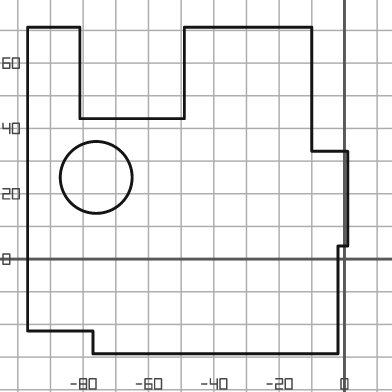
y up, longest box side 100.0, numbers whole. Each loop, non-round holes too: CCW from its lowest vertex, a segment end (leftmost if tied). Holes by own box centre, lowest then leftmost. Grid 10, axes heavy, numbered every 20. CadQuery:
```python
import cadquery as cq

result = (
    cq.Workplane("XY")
    .moveTo(-77.0, -29.0)
    .lineTo(-2.0, -29.0)
    .lineTo(-2.0, 4.0)
    .lineTo(1.0, 4.0)
    .lineTo(1.0, 33.0)
    .lineTo(-10.0, 33.0)
    .lineTo(-10.0, 71.0)
    .lineTo(-49.0, 71.0)
    .lineTo(-49.0, 43.0)
    .lineTo(-81.0, 43.0)
    .lineTo(-81.0, 71.0)
    .lineTo(-97.0, 71.0)
    .lineTo(-97.0, -22.0)
    .lineTo(-77.0, -22.0)
    .close()
    .moveTo(-76.0, 25.0)
    .circle(11.0)
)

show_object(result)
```